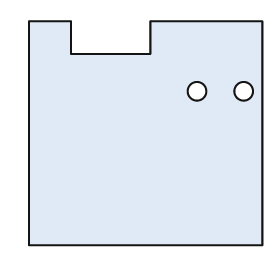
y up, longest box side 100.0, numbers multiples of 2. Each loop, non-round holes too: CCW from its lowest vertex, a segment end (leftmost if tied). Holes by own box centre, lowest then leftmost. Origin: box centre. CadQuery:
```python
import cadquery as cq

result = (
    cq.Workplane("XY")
    .moveTo(-50.0, -48.0)
    .lineTo(50.0, -48.0)
    .lineTo(50.0, 48.0)
    .lineTo(2.0, 48.0)
    .lineTo(2.0, 34.0)
    .lineTo(-32.0, 34.0)
    .lineTo(-32.0, 48.0)
    .lineTo(-50.0, 48.0)
    .close()
    .moveTo(22.0, 18.0)
    .circle(4.0)
    .moveTo(42.0, 18.0)
    .circle(4.0)
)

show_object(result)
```